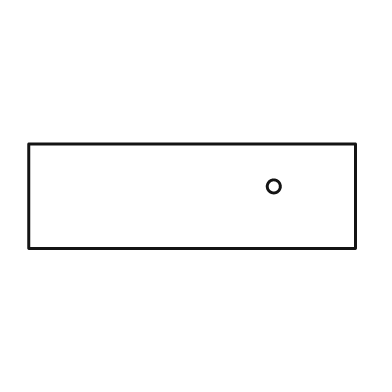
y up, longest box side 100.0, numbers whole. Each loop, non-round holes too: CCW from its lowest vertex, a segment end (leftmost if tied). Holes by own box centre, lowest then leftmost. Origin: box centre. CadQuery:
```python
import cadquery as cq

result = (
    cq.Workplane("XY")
    .moveTo(-50.0, -16.0)
    .lineTo(50.0, -16.0)
    .lineTo(50.0, 16.0)
    .lineTo(-50.0, 16.0)
    .close()
    .moveTo(25.0, 3.0)
    .circle(2.0)
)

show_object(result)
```